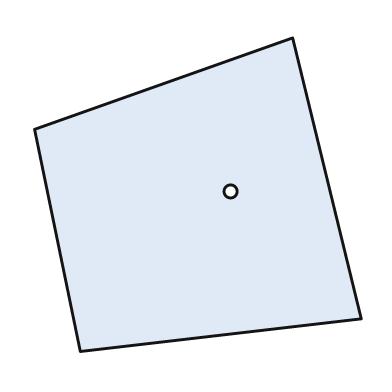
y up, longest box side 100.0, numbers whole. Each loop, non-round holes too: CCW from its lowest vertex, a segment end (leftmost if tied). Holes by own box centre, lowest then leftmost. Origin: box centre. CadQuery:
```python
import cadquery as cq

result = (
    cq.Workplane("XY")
    .moveTo(-36.0, -48.0)
    .lineTo(50.0, -38.0)
    .lineTo(29.0, 48.0)
    .lineTo(-50.0, 20.0)
    .close()
    .moveTo(10.0, 1.0)
    .circle(2.0)
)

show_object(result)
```